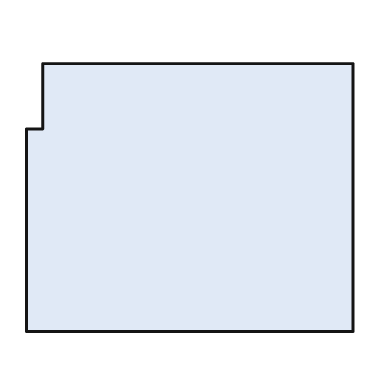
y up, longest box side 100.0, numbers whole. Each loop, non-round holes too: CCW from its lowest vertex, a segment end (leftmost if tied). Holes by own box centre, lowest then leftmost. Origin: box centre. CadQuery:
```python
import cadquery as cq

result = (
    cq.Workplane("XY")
    .moveTo(-50.0, -41.0)
    .lineTo(50.0, -41.0)
    .lineTo(50.0, 41.0)
    .lineTo(-45.0, 41.0)
    .lineTo(-45.0, 21.0)
    .lineTo(-50.0, 21.0)
    .close()
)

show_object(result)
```